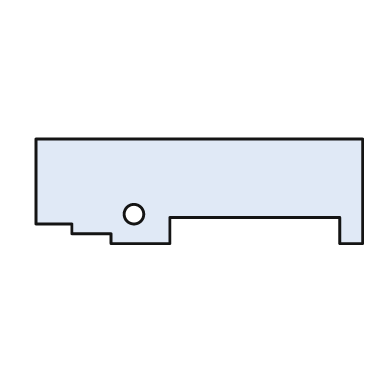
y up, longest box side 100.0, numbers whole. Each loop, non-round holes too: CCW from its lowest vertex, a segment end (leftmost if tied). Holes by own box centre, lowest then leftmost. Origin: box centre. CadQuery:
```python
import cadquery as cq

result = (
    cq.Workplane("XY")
    .moveTo(-27.0, -16.0)
    .lineTo(-9.0, -16.0)
    .lineTo(-9.0, -8.0)
    .lineTo(43.0, -8.0)
    .lineTo(43.0, -16.0)
    .lineTo(50.0, -16.0)
    .lineTo(50.0, 16.0)
    .lineTo(-50.0, 16.0)
    .lineTo(-50.0, -10.0)
    .lineTo(-39.0, -10.0)
    .lineTo(-39.0, -13.0)
    .lineTo(-27.0, -13.0)
    .close()
    .moveTo(-20.0, -7.0)
    .circle(3.0)
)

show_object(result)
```